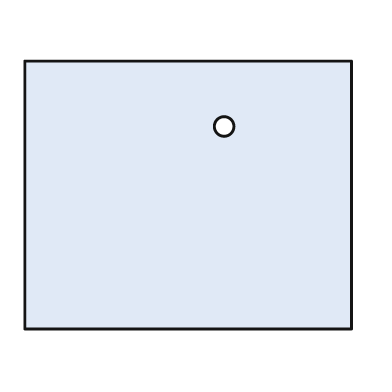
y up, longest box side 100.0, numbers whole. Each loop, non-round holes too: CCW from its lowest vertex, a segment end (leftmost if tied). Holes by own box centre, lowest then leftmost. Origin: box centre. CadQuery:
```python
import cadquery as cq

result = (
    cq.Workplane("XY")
    .moveTo(-50.0, -41.0)
    .lineTo(50.0, -41.0)
    .lineTo(50.0, 41.0)
    .lineTo(-50.0, 41.0)
    .close()
    .moveTo(11.0, 21.0)
    .circle(3.0)
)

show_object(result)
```